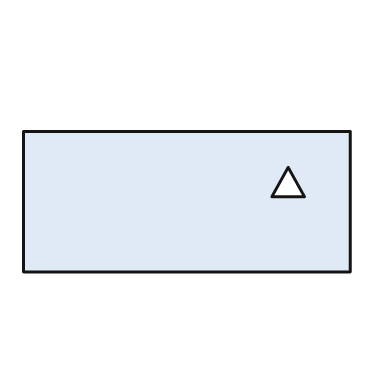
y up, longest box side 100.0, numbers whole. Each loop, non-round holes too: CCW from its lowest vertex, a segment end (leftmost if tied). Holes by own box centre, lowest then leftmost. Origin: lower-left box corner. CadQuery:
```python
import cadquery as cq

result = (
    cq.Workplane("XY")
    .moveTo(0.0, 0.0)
    .lineTo(100.0, 0.0)
    .lineTo(100.0, 43.0)
    .lineTo(0.0, 43.0)
    .close()
    .moveTo(76.0, 23.0)
    .lineTo(86.0, 23.0)
    .lineTo(81.0, 32.0)
    .close()
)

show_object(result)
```